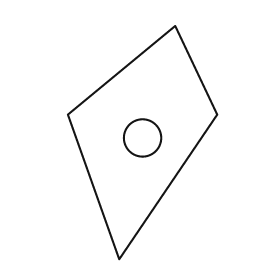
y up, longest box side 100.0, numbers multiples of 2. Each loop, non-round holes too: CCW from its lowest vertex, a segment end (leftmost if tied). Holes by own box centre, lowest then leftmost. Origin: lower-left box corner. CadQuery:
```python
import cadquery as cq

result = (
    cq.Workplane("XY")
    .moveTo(22.0, 0.0)
    .lineTo(64.0, 62.0)
    .lineTo(46.0, 100.0)
    .lineTo(0.0, 62.0)
    .close()
    .moveTo(32.0, 52.0)
    .circle(8.0)
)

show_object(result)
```